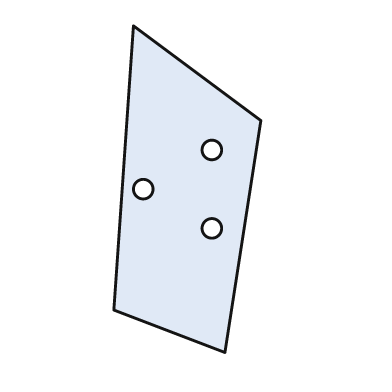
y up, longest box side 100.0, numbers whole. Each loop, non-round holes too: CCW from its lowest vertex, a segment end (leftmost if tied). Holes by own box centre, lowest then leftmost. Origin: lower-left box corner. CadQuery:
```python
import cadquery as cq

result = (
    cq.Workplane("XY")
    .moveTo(34.0, 0.0)
    .lineTo(45.0, 71.0)
    .lineTo(6.0, 100.0)
    .lineTo(0.0, 13.0)
    .close()
    .moveTo(30.0, 38.0)
    .circle(3.0)
    .moveTo(9.0, 50.0)
    .circle(3.0)
    .moveTo(30.0, 62.0)
    .circle(3.0)
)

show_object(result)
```